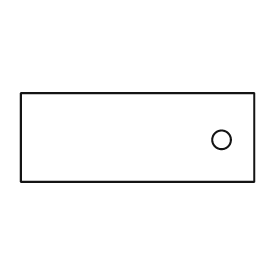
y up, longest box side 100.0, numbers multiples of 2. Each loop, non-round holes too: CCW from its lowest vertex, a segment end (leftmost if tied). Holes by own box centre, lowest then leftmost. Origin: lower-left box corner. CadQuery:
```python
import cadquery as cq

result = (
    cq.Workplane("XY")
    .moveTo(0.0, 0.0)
    .lineTo(100.0, 0.0)
    .lineTo(100.0, 38.0)
    .lineTo(0.0, 38.0)
    .close()
    .moveTo(86.0, 18.0)
    .circle(4.0)
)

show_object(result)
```